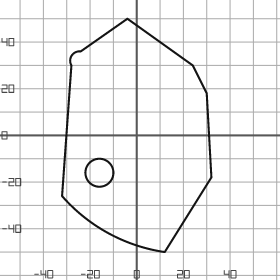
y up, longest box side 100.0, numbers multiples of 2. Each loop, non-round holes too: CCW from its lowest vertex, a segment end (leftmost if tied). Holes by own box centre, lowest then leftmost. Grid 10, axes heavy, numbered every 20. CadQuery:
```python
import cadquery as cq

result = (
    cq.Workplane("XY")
    .moveTo(12.0, -50.0)
    .lineTo(32.0, -18.0)
    .lineTo(30.0, 18.0)
    .lineTo(24.0, 30.0)
    .lineTo(-4.0, 50.0)
    .lineTo(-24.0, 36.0)
    .threePointArc((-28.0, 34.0), (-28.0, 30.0))
    .lineTo(-32.0, -26.0)
    .threePointArc((-12.0, -42.0), (12.0, -50.0))
    .close()
    .moveTo(-16.0, -16.0)
    .circle(6.0)
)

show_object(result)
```